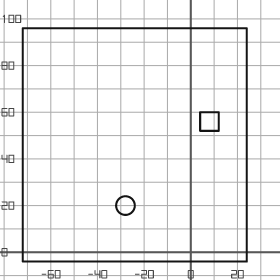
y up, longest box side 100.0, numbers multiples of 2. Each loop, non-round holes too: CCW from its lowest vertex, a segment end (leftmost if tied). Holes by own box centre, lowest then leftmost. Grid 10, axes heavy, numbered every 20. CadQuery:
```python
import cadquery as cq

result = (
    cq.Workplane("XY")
    .moveTo(-72.0, -4.0)
    .lineTo(24.0, -4.0)
    .lineTo(24.0, 96.0)
    .lineTo(-72.0, 96.0)
    .close()
    .moveTo(-28.0, 20.0)
    .circle(4.0)
    .moveTo(4.0, 52.0)
    .lineTo(12.0, 52.0)
    .lineTo(12.0, 60.0)
    .lineTo(4.0, 60.0)
    .close()
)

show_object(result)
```